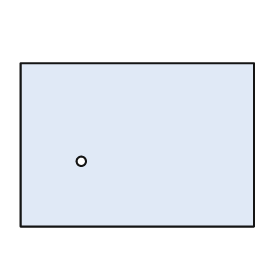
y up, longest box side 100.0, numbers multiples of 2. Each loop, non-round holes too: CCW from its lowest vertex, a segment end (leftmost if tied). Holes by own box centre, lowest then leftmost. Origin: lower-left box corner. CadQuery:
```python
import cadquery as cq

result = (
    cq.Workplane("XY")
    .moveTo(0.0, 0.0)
    .lineTo(100.0, 0.0)
    .lineTo(100.0, 70.0)
    .lineTo(0.0, 70.0)
    .close()
    .moveTo(26.0, 28.0)
    .circle(2.0)
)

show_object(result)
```